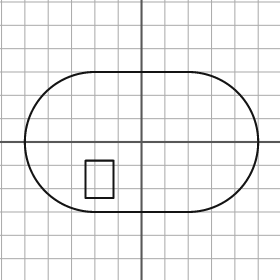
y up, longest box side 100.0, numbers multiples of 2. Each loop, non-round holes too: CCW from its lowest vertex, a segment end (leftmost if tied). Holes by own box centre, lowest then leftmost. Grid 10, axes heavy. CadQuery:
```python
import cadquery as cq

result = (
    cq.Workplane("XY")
    .moveTo(-20.0, -30.0)
    .lineTo(20.0, -30.0)
    .threePointArc((50.0, 0.0), (20.0, 30.0))
    .lineTo(-20.0, 30.0)
    .threePointArc((-50.0, 0.0), (-20.0, -30.0))
    .close()
    .moveTo(-24.0, -24.0)
    .lineTo(-12.0, -24.0)
    .lineTo(-12.0, -8.0)
    .lineTo(-24.0, -8.0)
    .close()
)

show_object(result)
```